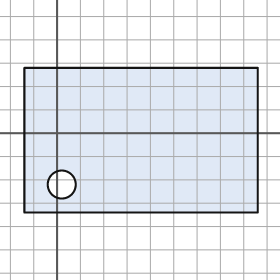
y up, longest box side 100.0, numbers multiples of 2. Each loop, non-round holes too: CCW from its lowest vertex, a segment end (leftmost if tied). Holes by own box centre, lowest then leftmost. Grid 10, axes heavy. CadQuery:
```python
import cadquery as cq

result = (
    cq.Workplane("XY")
    .moveTo(-14.0, -34.0)
    .lineTo(86.0, -34.0)
    .lineTo(86.0, 28.0)
    .lineTo(-14.0, 28.0)
    .close()
    .moveTo(2.0, -22.0)
    .circle(6.0)
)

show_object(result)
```